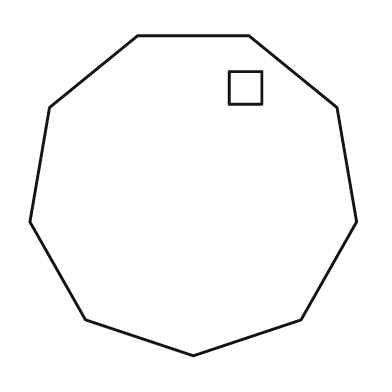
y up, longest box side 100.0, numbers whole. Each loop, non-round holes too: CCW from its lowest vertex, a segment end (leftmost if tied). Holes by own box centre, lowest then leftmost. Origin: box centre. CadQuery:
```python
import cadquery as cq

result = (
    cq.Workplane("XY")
    .moveTo(0.0, -49.0)
    .lineTo(33.0, -38.0)
    .lineTo(50.0, -8.0)
    .lineTo(44.0, 27.0)
    .lineTo(17.0, 49.0)
    .lineTo(-17.0, 49.0)
    .lineTo(-44.0, 27.0)
    .lineTo(-50.0, -8.0)
    .lineTo(-33.0, -38.0)
    .close()
    .moveTo(11.0, 28.0)
    .lineTo(21.0, 28.0)
    .lineTo(21.0, 38.0)
    .lineTo(11.0, 38.0)
    .close()
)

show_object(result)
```